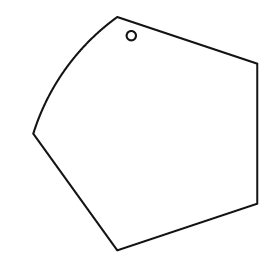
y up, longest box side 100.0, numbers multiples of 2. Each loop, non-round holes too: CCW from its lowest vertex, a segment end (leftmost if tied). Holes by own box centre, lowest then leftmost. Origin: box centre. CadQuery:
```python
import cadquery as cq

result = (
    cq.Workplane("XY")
    .moveTo(-12.0, -50.0)
    .lineTo(48.0, -30.0)
    .lineTo(48.0, 30.0)
    .lineTo(-12.0, 50.0)
    .threePointArc((-34.0, 28.0), (-48.0, 0.0))
    .close()
    .moveTo(-6.0, 42.0)
    .circle(2.0)
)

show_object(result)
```